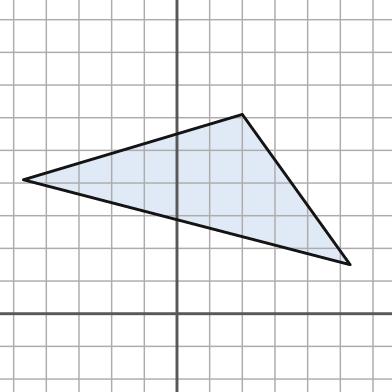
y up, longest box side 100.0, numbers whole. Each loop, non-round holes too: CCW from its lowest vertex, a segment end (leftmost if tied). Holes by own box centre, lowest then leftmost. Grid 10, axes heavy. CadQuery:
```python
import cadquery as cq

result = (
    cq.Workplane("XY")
    .moveTo(53.0, 15.0)
    .lineTo(20.0, 61.0)
    .lineTo(-47.0, 41.0)
    .close()
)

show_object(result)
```